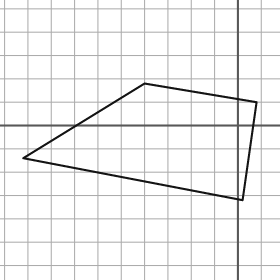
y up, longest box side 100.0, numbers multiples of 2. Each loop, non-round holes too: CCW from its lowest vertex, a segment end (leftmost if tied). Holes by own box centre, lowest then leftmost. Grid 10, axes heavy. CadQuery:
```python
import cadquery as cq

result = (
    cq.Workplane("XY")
    .moveTo(2.0, -32.0)
    .lineTo(8.0, 10.0)
    .lineTo(-40.0, 18.0)
    .lineTo(-92.0, -14.0)
    .close()
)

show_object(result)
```